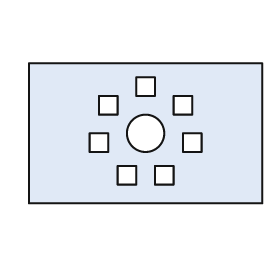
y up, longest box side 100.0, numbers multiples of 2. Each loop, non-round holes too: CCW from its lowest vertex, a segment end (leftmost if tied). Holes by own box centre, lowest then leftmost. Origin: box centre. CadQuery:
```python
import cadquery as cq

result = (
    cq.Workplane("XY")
    .moveTo(-50.0, -30.0)
    .lineTo(50.0, -30.0)
    .lineTo(50.0, 30.0)
    .lineTo(-50.0, 30.0)
    .close()
    .moveTo(-12.0, -22.0)
    .lineTo(-4.0, -22.0)
    .lineTo(-4.0, -14.0)
    .lineTo(-12.0, -14.0)
    .close()
    .moveTo(4.0, -22.0)
    .lineTo(12.0, -22.0)
    .lineTo(12.0, -14.0)
    .lineTo(4.0, -14.0)
    .close()
    .moveTo(-24.0, -8.0)
    .lineTo(-16.0, -8.0)
    .lineTo(-16.0, 0.0)
    .lineTo(-24.0, 0.0)
    .close()
    .moveTo(16.0, -8.0)
    .lineTo(24.0, -8.0)
    .lineTo(24.0, 0.0)
    .lineTo(16.0, 0.0)
    .close()
    .moveTo(0.0, 0.0)
    .circle(8.0)
    .moveTo(-20.0, 8.0)
    .lineTo(-12.0, 8.0)
    .lineTo(-12.0, 16.0)
    .lineTo(-20.0, 16.0)
    .close()
    .moveTo(12.0, 8.0)
    .lineTo(20.0, 8.0)
    .lineTo(20.0, 16.0)
    .lineTo(12.0, 16.0)
    .close()
    .moveTo(-4.0, 16.0)
    .lineTo(4.0, 16.0)
    .lineTo(4.0, 24.0)
    .lineTo(-4.0, 24.0)
    .close()
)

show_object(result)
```